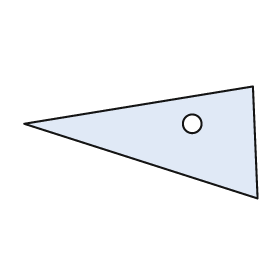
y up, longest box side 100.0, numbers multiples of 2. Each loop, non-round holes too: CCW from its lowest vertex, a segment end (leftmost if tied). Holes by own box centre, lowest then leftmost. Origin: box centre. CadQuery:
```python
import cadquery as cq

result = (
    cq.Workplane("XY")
    .moveTo(50.0, -24.0)
    .lineTo(48.0, 24.0)
    .lineTo(-50.0, 8.0)
    .close()
    .moveTo(22.0, 8.0)
    .circle(4.0)
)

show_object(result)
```